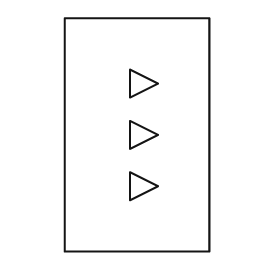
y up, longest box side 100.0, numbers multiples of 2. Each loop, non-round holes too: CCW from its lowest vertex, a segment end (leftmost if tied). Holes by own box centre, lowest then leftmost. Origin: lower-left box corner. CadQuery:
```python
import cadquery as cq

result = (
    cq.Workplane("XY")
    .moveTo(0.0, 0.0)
    .lineTo(62.0, 0.0)
    .lineTo(62.0, 100.0)
    .lineTo(0.0, 100.0)
    .close()
    .moveTo(28.0, 22.0)
    .lineTo(40.0, 28.0)
    .lineTo(28.0, 34.0)
    .close()
    .moveTo(28.0, 44.0)
    .lineTo(40.0, 50.0)
    .lineTo(28.0, 56.0)
    .close()
    .moveTo(28.0, 66.0)
    .lineTo(40.0, 72.0)
    .lineTo(28.0, 78.0)
    .close()
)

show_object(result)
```